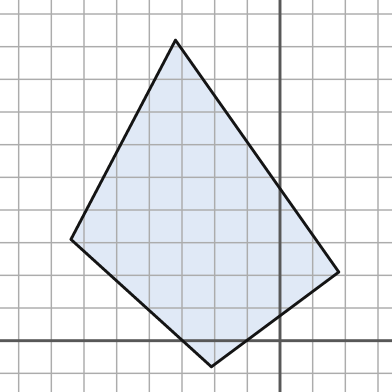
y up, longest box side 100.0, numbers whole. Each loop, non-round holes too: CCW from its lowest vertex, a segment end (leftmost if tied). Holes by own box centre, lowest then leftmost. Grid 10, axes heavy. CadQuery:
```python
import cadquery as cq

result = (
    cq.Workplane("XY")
    .moveTo(-21.0, -8.0)
    .lineTo(18.0, 21.0)
    .lineTo(-32.0, 92.0)
    .lineTo(-64.0, 31.0)
    .close()
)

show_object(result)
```